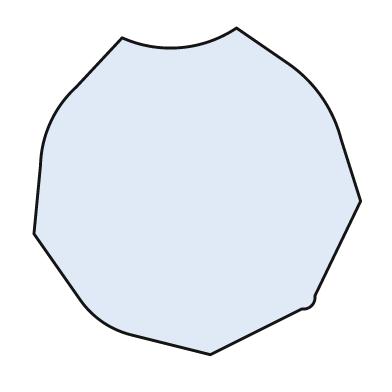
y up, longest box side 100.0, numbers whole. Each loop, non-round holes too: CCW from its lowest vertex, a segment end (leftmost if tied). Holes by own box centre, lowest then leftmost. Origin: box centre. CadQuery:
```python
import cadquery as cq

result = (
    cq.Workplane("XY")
    .moveTo(4.0, -50.0)
    .lineTo(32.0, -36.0)
    .threePointArc((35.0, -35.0), (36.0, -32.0))
    .lineTo(50.0, -3.0)
    .lineTo(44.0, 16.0)
    .threePointArc((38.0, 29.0), (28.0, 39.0))
    .lineTo(12.0, 50.0)
    .threePointArc((-5.0, 44.0), (-23.0, 47.0))
    .lineTo(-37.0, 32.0)
    .threePointArc((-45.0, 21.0), (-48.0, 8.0))
    .lineTo(-50.0, -13.0)
    .lineTo(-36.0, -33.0)
    .threePointArc((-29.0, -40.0), (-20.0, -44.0))
    .close()
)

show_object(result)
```